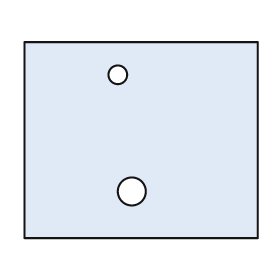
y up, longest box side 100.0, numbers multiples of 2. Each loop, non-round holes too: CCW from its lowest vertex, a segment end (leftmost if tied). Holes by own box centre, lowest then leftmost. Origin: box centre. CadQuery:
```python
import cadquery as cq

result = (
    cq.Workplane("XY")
    .moveTo(-50.0, -42.0)
    .lineTo(50.0, -42.0)
    .lineTo(50.0, 42.0)
    .lineTo(-50.0, 42.0)
    .close()
    .moveTo(-4.0, -22.0)
    .circle(6.0)
    .moveTo(-10.0, 28.0)
    .circle(4.0)
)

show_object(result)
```